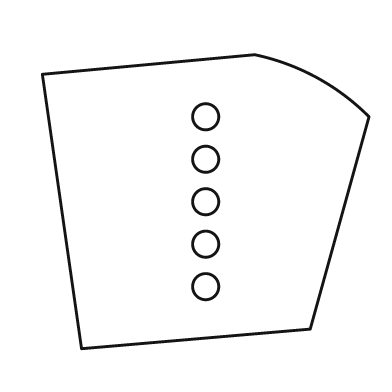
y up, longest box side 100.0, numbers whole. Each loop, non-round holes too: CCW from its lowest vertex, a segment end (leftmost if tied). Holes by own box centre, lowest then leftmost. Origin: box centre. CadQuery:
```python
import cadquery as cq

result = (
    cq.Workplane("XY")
    .moveTo(-38.0, -45.0)
    .lineTo(32.0, -39.0)
    .lineTo(50.0, 26.0)
    .threePointArc((34.0, 38.0), (15.0, 45.0))
    .lineTo(-50.0, 39.0)
    .close()
    .moveTo(0.0, -26.0)
    .circle(4.0)
    .moveTo(0.0, -13.0)
    .circle(4.0)
    .moveTo(0.0, 0.0)
    .circle(4.0)
    .moveTo(0.0, 13.0)
    .circle(4.0)
    .moveTo(0.0, 26.0)
    .circle(4.0)
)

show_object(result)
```